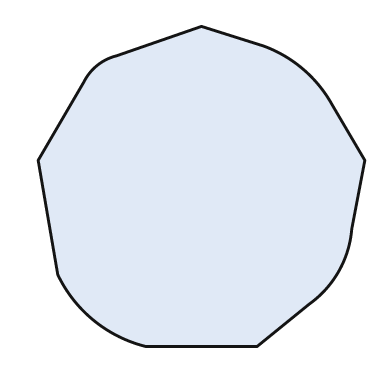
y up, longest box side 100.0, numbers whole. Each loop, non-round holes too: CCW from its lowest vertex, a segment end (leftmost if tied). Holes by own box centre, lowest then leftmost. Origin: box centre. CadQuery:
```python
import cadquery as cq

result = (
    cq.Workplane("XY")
    .moveTo(-17.0, -49.0)
    .lineTo(17.0, -49.0)
    .lineTo(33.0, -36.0)
    .threePointArc((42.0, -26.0), (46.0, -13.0))
    .lineTo(50.0, 8.0)
    .lineTo(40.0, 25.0)
    .threePointArc((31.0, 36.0), (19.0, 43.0))
    .lineTo(0.0, 49.0)
    .lineTo(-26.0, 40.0)
    .threePointArc((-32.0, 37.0), (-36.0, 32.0))
    .lineTo(-50.0, 8.0)
    .lineTo(-44.0, -27.0)
    .threePointArc((-33.0, -41.0), (-17.0, -49.0))
    .close()
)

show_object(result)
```